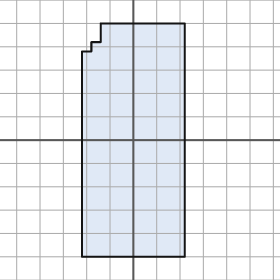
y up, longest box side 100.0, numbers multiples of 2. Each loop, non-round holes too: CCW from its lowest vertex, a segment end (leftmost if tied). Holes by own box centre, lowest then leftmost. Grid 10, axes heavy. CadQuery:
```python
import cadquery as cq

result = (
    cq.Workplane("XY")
    .moveTo(-22.0, -50.0)
    .lineTo(22.0, -50.0)
    .lineTo(22.0, 50.0)
    .lineTo(-14.0, 50.0)
    .lineTo(-14.0, 42.0)
    .lineTo(-18.0, 42.0)
    .lineTo(-18.0, 38.0)
    .lineTo(-22.0, 38.0)
    .close()
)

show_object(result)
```